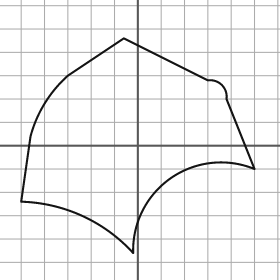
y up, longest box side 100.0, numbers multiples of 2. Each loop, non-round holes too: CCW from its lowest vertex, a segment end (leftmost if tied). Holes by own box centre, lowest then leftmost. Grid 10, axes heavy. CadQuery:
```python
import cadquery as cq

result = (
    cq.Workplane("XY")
    .moveTo(-2.0, -46.0)
    .threePointArc((14.0, -14.0), (50.0, -10.0))
    .lineTo(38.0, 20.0)
    .threePointArc((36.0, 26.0), (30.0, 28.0))
    .lineTo(-6.0, 46.0)
    .lineTo(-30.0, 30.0)
    .threePointArc((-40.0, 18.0), (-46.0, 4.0))
    .lineTo(-50.0, -24.0)
    .threePointArc((-24.0, -30.0), (-2.0, -46.0))
    .close()
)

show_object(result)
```